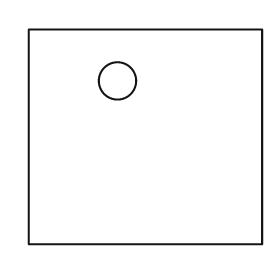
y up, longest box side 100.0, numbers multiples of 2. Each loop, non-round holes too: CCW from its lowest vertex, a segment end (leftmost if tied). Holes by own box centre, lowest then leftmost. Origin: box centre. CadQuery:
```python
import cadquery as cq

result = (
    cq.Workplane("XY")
    .moveTo(-50.0, -46.0)
    .lineTo(50.0, -46.0)
    .lineTo(50.0, 46.0)
    .lineTo(-50.0, 46.0)
    .close()
    .moveTo(-12.0, 24.0)
    .circle(8.0)
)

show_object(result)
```